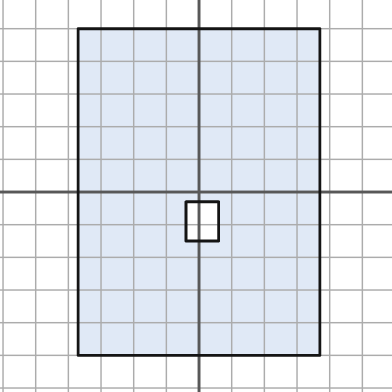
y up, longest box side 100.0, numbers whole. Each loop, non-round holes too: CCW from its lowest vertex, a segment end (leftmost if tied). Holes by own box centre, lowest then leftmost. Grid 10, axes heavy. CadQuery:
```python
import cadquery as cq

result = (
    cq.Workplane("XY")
    .moveTo(-37.0, -50.0)
    .lineTo(37.0, -50.0)
    .lineTo(37.0, 50.0)
    .lineTo(-37.0, 50.0)
    .close()
    .moveTo(-4.0, -15.0)
    .lineTo(6.0, -15.0)
    .lineTo(6.0, -3.0)
    .lineTo(-4.0, -3.0)
    .close()
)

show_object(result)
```